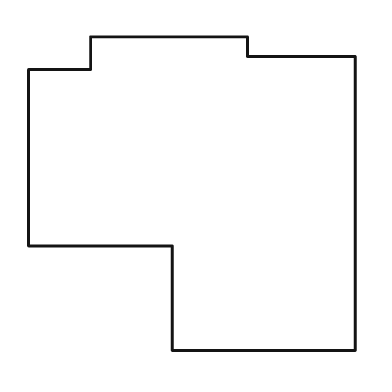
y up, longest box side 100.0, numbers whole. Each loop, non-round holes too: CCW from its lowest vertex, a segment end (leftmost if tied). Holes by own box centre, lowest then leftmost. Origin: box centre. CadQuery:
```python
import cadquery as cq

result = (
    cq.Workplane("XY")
    .moveTo(-6.0, -48.0)
    .lineTo(50.0, -48.0)
    .lineTo(50.0, 42.0)
    .lineTo(17.0, 42.0)
    .lineTo(17.0, 48.0)
    .lineTo(-31.0, 48.0)
    .lineTo(-31.0, 38.0)
    .lineTo(-50.0, 38.0)
    .lineTo(-50.0, -16.0)
    .lineTo(-6.0, -16.0)
    .close()
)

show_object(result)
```